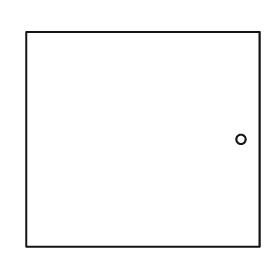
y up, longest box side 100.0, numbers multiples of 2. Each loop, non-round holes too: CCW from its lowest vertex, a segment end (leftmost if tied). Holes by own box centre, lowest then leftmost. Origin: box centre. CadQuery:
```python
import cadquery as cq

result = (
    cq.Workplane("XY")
    .moveTo(-50.0, -46.0)
    .lineTo(50.0, -46.0)
    .lineTo(50.0, 46.0)
    .lineTo(-50.0, 46.0)
    .close()
    .moveTo(42.0, 0.0)
    .circle(2.0)
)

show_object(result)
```